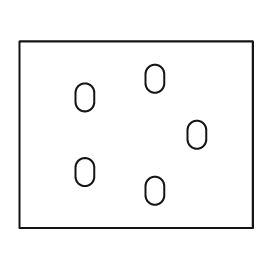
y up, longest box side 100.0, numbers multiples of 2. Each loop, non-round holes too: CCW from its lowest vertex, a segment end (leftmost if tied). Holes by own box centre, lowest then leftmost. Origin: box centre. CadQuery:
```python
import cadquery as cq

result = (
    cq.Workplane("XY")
    .moveTo(-50.0, -40.0)
    .lineTo(50.0, -40.0)
    .lineTo(50.0, 40.0)
    .lineTo(-50.0, 40.0)
    .close()
    .moveTo(4.0, -26.0)
    .threePointArc((8.0, -30.0), (12.0, -26.0))
    .lineTo(12.0, -22.0)
    .threePointArc((8.0, -18.0), (4.0, -22.0))
    .close()
    .moveTo(-26.0, -18.0)
    .threePointArc((-22.0, -22.0), (-18.0, -18.0))
    .lineTo(-18.0, -14.0)
    .threePointArc((-22.0, -10.0), (-26.0, -14.0))
    .close()
    .moveTo(22.0, -2.0)
    .threePointArc((26.0, -6.0), (30.0, -2.0))
    .lineTo(30.0, 2.0)
    .threePointArc((26.0, 6.0), (22.0, 2.0))
    .close()
    .moveTo(-26.0, 14.0)
    .threePointArc((-22.0, 10.0), (-18.0, 14.0))
    .lineTo(-18.0, 18.0)
    .threePointArc((-22.0, 22.0), (-26.0, 18.0))
    .close()
    .moveTo(4.0, 22.0)
    .threePointArc((8.0, 18.0), (12.0, 22.0))
    .lineTo(12.0, 26.0)
    .threePointArc((8.0, 30.0), (4.0, 26.0))
    .close()
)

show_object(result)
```